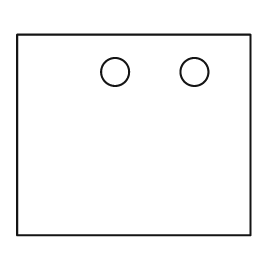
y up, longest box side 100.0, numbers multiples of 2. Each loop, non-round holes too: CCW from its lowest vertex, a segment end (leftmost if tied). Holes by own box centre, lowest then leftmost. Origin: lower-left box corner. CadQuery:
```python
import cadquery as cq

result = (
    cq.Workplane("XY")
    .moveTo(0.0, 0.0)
    .lineTo(100.0, 0.0)
    .lineTo(100.0, 86.0)
    .lineTo(0.0, 86.0)
    .close()
    .moveTo(42.0, 70.0)
    .circle(6.0)
    .moveTo(76.0, 70.0)
    .circle(6.0)
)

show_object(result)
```